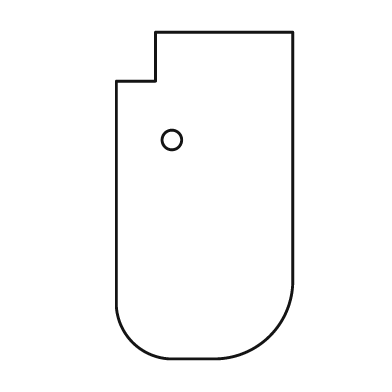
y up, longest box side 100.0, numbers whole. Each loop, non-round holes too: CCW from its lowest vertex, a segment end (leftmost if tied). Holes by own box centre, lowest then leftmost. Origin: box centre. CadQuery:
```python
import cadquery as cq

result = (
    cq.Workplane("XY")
    .moveTo(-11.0, -50.0)
    .lineTo(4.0, -50.0)
    .threePointArc((20.0, -43.0), (27.0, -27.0))
    .lineTo(27.0, 50.0)
    .lineTo(-15.0, 50.0)
    .lineTo(-15.0, 35.0)
    .lineTo(-27.0, 35.0)
    .lineTo(-27.0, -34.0)
    .threePointArc((-22.0, -45.0), (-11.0, -50.0))
    .close()
    .moveTo(-10.0, 17.0)
    .circle(3.0)
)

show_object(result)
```